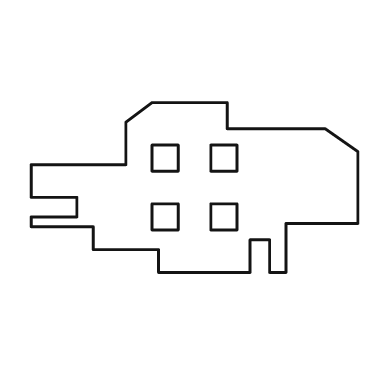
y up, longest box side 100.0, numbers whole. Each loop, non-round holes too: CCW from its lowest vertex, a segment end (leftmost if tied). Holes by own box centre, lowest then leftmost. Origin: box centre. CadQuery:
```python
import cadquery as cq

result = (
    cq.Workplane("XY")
    .moveTo(-11.0, -26.0)
    .lineTo(17.0, -26.0)
    .lineTo(17.0, -16.0)
    .lineTo(23.0, -16.0)
    .lineTo(23.0, -26.0)
    .lineTo(28.0, -26.0)
    .lineTo(28.0, -11.0)
    .lineTo(50.0, -11.0)
    .lineTo(50.0, 11.0)
    .lineTo(40.0, 18.0)
    .lineTo(10.0, 18.0)
    .lineTo(10.0, 26.0)
    .lineTo(-13.0, 26.0)
    .lineTo(-21.0, 20.0)
    .lineTo(-21.0, 7.0)
    .lineTo(-50.0, 7.0)
    .lineTo(-50.0, -3.0)
    .lineTo(-36.0, -3.0)
    .lineTo(-36.0, -9.0)
    .lineTo(-50.0, -9.0)
    .lineTo(-50.0, -12.0)
    .lineTo(-31.0, -12.0)
    .lineTo(-31.0, -19.0)
    .lineTo(-11.0, -19.0)
    .close()
    .moveTo(-13.0, -13.0)
    .lineTo(-5.0, -13.0)
    .lineTo(-5.0, -5.0)
    .lineTo(-13.0, -5.0)
    .close()
    .moveTo(5.0, -13.0)
    .lineTo(13.0, -13.0)
    .lineTo(13.0, -5.0)
    .lineTo(5.0, -5.0)
    .close()
    .moveTo(-13.0, 5.0)
    .lineTo(-5.0, 5.0)
    .lineTo(-5.0, 13.0)
    .lineTo(-13.0, 13.0)
    .close()
    .moveTo(5.0, 5.0)
    .lineTo(13.0, 5.0)
    .lineTo(13.0, 13.0)
    .lineTo(5.0, 13.0)
    .close()
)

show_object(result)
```